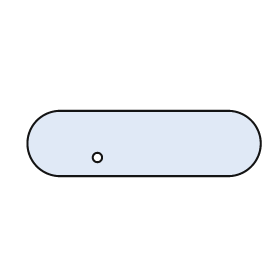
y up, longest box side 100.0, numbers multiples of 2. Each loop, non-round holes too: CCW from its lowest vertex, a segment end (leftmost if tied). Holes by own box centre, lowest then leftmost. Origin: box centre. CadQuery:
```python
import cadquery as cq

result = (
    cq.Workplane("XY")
    .moveTo(-36.0, -14.0)
    .lineTo(36.0, -14.0)
    .threePointArc((50.0, 0.0), (36.0, 14.0))
    .lineTo(-36.0, 14.0)
    .threePointArc((-50.0, 0.0), (-36.0, -14.0))
    .close()
    .moveTo(-20.0, -6.0)
    .circle(2.0)
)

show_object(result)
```